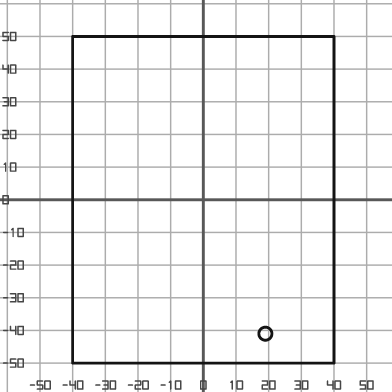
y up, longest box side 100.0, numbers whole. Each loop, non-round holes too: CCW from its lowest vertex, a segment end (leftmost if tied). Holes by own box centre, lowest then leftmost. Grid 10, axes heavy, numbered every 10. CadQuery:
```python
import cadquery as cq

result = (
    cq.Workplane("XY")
    .moveTo(-40.0, -50.0)
    .lineTo(40.0, -50.0)
    .lineTo(40.0, 50.0)
    .lineTo(-40.0, 50.0)
    .close()
    .moveTo(19.0, -41.0)
    .circle(2.0)
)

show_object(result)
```